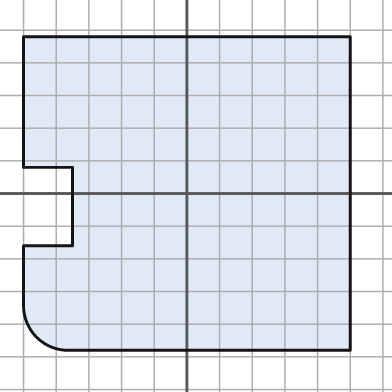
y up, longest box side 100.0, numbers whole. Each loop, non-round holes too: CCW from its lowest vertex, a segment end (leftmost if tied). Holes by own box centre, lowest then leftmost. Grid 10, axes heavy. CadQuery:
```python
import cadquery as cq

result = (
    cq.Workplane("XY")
    .moveTo(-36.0, -48.0)
    .lineTo(50.0, -48.0)
    .lineTo(50.0, 48.0)
    .lineTo(-50.0, 48.0)
    .lineTo(-50.0, 8.0)
    .lineTo(-35.0, 8.0)
    .lineTo(-35.0, -16.0)
    .lineTo(-50.0, -16.0)
    .lineTo(-50.0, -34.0)
    .threePointArc((-46.0, -44.0), (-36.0, -48.0))
    .close()
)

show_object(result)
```